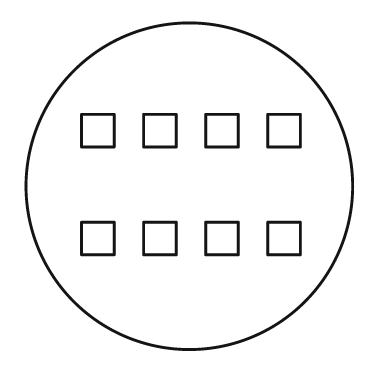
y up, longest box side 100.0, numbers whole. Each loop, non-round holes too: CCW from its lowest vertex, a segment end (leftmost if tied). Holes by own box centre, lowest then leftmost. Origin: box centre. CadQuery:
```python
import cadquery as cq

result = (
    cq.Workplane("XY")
    .moveTo(0.0, 0.0)
    .circle(50.0)
    .moveTo(-33.0, -21.0)
    .lineTo(-23.0, -21.0)
    .lineTo(-23.0, -11.0)
    .lineTo(-33.0, -11.0)
    .close()
    .moveTo(-14.0, -21.0)
    .lineTo(-4.0, -21.0)
    .lineTo(-4.0, -11.0)
    .lineTo(-14.0, -11.0)
    .close()
    .moveTo(5.0, -21.0)
    .lineTo(15.0, -21.0)
    .lineTo(15.0, -11.0)
    .lineTo(5.0, -11.0)
    .close()
    .moveTo(24.0, -21.0)
    .lineTo(34.0, -21.0)
    .lineTo(34.0, -11.0)
    .lineTo(24.0, -11.0)
    .close()
    .moveTo(-33.0, 12.0)
    .lineTo(-23.0, 12.0)
    .lineTo(-23.0, 22.0)
    .lineTo(-33.0, 22.0)
    .close()
    .moveTo(-14.0, 12.0)
    .lineTo(-4.0, 12.0)
    .lineTo(-4.0, 22.0)
    .lineTo(-14.0, 22.0)
    .close()
    .moveTo(5.0, 12.0)
    .lineTo(15.0, 12.0)
    .lineTo(15.0, 22.0)
    .lineTo(5.0, 22.0)
    .close()
    .moveTo(24.0, 12.0)
    .lineTo(34.0, 12.0)
    .lineTo(34.0, 22.0)
    .lineTo(24.0, 22.0)
    .close()
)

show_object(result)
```